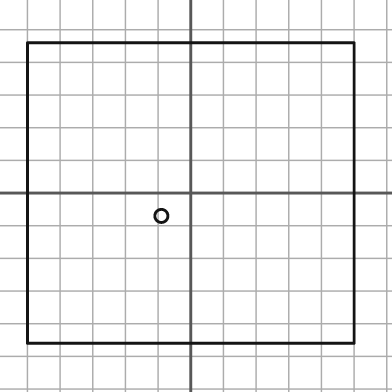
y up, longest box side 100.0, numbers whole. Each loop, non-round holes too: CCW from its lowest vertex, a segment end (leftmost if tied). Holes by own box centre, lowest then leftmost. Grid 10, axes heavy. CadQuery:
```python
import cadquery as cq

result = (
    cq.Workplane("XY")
    .moveTo(-50.0, -46.0)
    .lineTo(50.0, -46.0)
    .lineTo(50.0, 46.0)
    .lineTo(-50.0, 46.0)
    .close()
    .moveTo(-9.0, -7.0)
    .circle(2.0)
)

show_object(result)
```